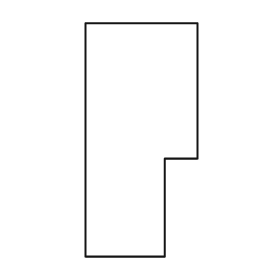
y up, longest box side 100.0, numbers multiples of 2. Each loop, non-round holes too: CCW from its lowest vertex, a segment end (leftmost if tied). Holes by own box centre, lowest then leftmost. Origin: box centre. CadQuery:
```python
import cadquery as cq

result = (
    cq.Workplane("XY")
    .moveTo(-24.0, -50.0)
    .lineTo(10.0, -50.0)
    .lineTo(10.0, -8.0)
    .lineTo(24.0, -8.0)
    .lineTo(24.0, 50.0)
    .lineTo(-24.0, 50.0)
    .close()
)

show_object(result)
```